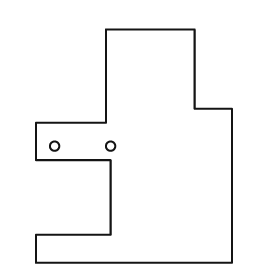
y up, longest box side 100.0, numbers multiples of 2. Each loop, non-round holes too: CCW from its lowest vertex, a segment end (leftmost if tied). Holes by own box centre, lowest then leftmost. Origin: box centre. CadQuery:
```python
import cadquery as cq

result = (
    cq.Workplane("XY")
    .moveTo(-42.0, -50.0)
    .lineTo(42.0, -50.0)
    .lineTo(42.0, 16.0)
    .lineTo(26.0, 16.0)
    .lineTo(26.0, 50.0)
    .lineTo(-12.0, 50.0)
    .lineTo(-12.0, 10.0)
    .lineTo(-42.0, 10.0)
    .lineTo(-42.0, -6.0)
    .lineTo(-10.0, -6.0)
    .lineTo(-10.0, -38.0)
    .lineTo(-42.0, -38.0)
    .close()
    .moveTo(-34.0, 0.0)
    .circle(2.0)
    .moveTo(-10.0, 0.0)
    .circle(2.0)
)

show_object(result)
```